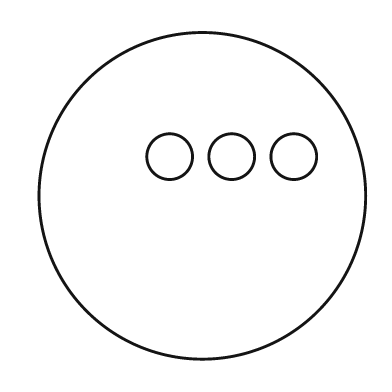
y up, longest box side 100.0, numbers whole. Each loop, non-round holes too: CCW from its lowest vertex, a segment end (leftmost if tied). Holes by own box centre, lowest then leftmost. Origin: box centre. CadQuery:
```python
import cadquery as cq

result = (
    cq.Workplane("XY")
    .moveTo(0.0, 0.0)
    .circle(50.0)
    .moveTo(-10.0, 12.0)
    .circle(7.0)
    .moveTo(9.0, 12.0)
    .circle(7.0)
    .moveTo(28.0, 12.0)
    .circle(7.0)
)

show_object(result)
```